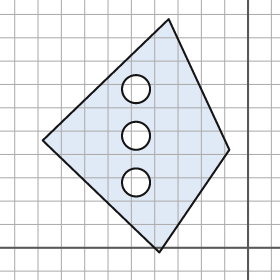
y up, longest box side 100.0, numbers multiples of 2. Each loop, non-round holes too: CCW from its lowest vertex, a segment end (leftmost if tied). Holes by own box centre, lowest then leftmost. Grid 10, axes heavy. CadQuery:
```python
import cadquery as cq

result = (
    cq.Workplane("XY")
    .moveTo(-38.0, -2.0)
    .lineTo(-8.0, 42.0)
    .lineTo(-34.0, 98.0)
    .lineTo(-88.0, 46.0)
    .close()
    .moveTo(-48.0, 28.0)
    .circle(6.0)
    .moveTo(-48.0, 48.0)
    .circle(6.0)
    .moveTo(-48.0, 68.0)
    .circle(6.0)
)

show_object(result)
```